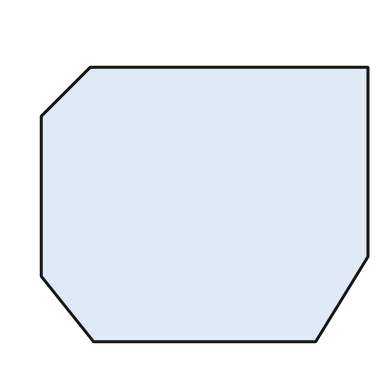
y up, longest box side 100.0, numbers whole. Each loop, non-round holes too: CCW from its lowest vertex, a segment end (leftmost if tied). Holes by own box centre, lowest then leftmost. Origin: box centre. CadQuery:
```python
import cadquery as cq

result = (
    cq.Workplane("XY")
    .moveTo(-34.0, -42.0)
    .lineTo(34.0, -42.0)
    .lineTo(50.0, -16.0)
    .lineTo(50.0, 42.0)
    .lineTo(-35.0, 42.0)
    .lineTo(-50.0, 27.0)
    .lineTo(-50.0, -22.0)
    .close()
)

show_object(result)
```